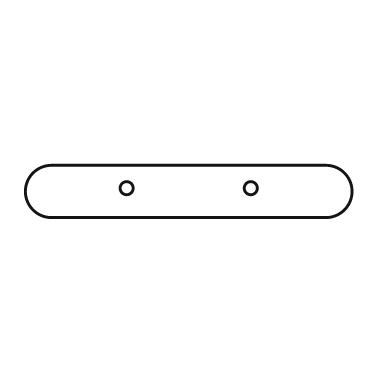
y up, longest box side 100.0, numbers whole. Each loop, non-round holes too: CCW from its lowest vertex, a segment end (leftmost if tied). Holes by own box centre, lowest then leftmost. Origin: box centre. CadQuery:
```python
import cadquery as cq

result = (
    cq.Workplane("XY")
    .moveTo(-42.0, -8.0)
    .lineTo(42.0, -8.0)
    .threePointArc((50.0, 0.0), (42.0, 8.0))
    .lineTo(-42.0, 8.0)
    .threePointArc((-50.0, 0.0), (-42.0, -8.0))
    .close()
    .moveTo(-19.0, 1.0)
    .circle(2.0)
    .moveTo(19.0, 1.0)
    .circle(2.0)
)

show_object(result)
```